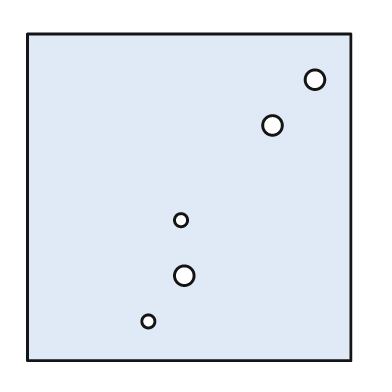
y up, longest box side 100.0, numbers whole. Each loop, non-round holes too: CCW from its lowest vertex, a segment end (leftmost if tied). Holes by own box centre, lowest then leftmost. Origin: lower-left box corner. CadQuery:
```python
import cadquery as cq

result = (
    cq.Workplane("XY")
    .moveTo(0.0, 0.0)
    .lineTo(99.0, 0.0)
    .lineTo(99.0, 100.0)
    .lineTo(0.0, 100.0)
    .close()
    .moveTo(37.0, 12.0)
    .circle(2.0)
    .moveTo(48.0, 26.0)
    .circle(3.0)
    .moveTo(47.0, 43.0)
    .circle(2.0)
    .moveTo(75.0, 72.0)
    .circle(3.0)
    .moveTo(88.0, 86.0)
    .circle(3.0)
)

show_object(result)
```